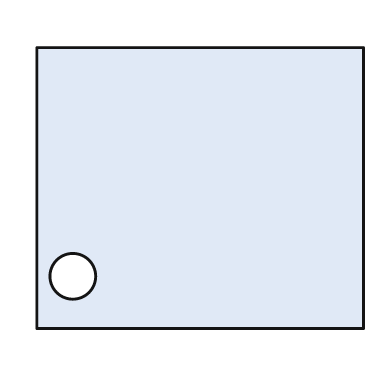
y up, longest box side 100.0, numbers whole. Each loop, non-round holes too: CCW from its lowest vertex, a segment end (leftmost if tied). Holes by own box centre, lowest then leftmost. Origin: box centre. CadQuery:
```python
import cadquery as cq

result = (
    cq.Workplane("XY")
    .moveTo(-50.0, -43.0)
    .lineTo(50.0, -43.0)
    .lineTo(50.0, 43.0)
    .lineTo(-50.0, 43.0)
    .close()
    .moveTo(-39.0, -27.0)
    .circle(7.0)
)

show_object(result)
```